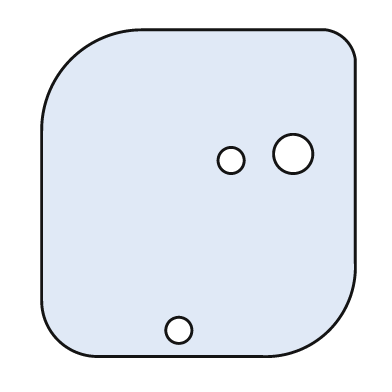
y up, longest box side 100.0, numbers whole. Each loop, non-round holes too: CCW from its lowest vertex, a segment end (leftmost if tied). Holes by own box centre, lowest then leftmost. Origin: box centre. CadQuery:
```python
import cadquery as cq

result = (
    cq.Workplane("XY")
    .moveTo(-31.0, -50.0)
    .lineTo(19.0, -50.0)
    .threePointArc((40.0, -42.0), (48.0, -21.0))
    .lineTo(48.0, 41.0)
    .threePointArc((45.0, 47.0), (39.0, 50.0))
    .lineTo(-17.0, 50.0)
    .threePointArc((-39.0, 41.0), (-48.0, 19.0))
    .lineTo(-48.0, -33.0)
    .threePointArc((-43.0, -45.0), (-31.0, -50.0))
    .close()
    .moveTo(-6.0, -42.0)
    .circle(4.0)
    .moveTo(10.0, 10.0)
    .circle(4.0)
    .moveTo(29.0, 12.0)
    .circle(6.0)
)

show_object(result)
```